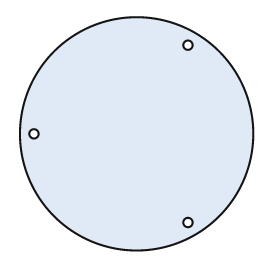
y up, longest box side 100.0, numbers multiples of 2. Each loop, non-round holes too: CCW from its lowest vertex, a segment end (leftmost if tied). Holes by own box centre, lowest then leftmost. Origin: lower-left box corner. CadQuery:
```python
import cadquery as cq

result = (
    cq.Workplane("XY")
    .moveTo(50.0, 50.0)
    .circle(50.0)
    .moveTo(72.0, 12.0)
    .circle(2.0)
    .moveTo(6.0, 50.0)
    .circle(2.0)
    .moveTo(72.0, 88.0)
    .circle(2.0)
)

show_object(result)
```